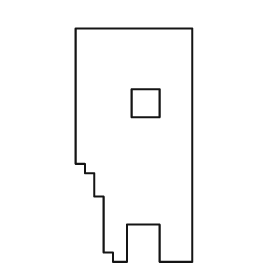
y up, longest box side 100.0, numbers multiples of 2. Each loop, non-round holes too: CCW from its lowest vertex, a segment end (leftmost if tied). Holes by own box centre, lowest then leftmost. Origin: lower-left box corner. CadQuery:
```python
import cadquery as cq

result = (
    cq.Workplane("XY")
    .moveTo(16.0, 0.0)
    .lineTo(22.0, 0.0)
    .lineTo(22.0, 16.0)
    .lineTo(36.0, 16.0)
    .lineTo(36.0, 0.0)
    .lineTo(50.0, 0.0)
    .lineTo(50.0, 100.0)
    .lineTo(0.0, 100.0)
    .lineTo(0.0, 42.0)
    .lineTo(4.0, 42.0)
    .lineTo(4.0, 38.0)
    .lineTo(8.0, 38.0)
    .lineTo(8.0, 28.0)
    .lineTo(12.0, 28.0)
    .lineTo(12.0, 4.0)
    .lineTo(16.0, 4.0)
    .close()
    .moveTo(24.0, 62.0)
    .lineTo(36.0, 62.0)
    .lineTo(36.0, 74.0)
    .lineTo(24.0, 74.0)
    .close()
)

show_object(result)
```